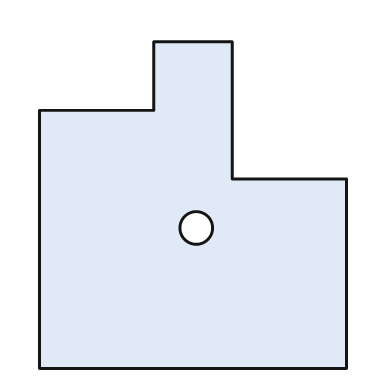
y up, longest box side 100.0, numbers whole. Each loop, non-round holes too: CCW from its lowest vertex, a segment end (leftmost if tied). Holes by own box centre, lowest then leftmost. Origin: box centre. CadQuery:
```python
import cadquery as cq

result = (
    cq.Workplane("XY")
    .moveTo(-47.0, -50.0)
    .lineTo(47.0, -50.0)
    .lineTo(47.0, 8.0)
    .lineTo(12.0, 8.0)
    .lineTo(12.0, 50.0)
    .lineTo(-12.0, 50.0)
    .lineTo(-12.0, 29.0)
    .lineTo(-47.0, 29.0)
    .close()
    .moveTo(1.0, -7.0)
    .circle(5.0)
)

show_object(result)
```